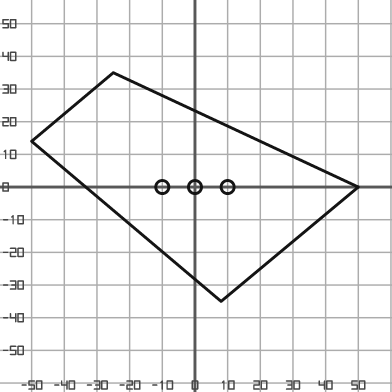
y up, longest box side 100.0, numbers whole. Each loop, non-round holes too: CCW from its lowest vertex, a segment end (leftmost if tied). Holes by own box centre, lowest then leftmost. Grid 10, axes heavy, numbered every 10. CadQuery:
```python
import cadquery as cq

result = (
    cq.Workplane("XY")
    .moveTo(8.0, -35.0)
    .lineTo(50.0, 0.0)
    .lineTo(-25.0, 35.0)
    .lineTo(-50.0, 14.0)
    .close()
    .moveTo(-10.0, 0.0)
    .circle(2.0)
    .moveTo(0.0, 0.0)
    .circle(2.0)
    .moveTo(10.0, 0.0)
    .circle(2.0)
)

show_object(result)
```